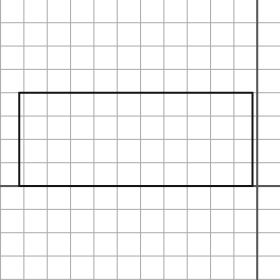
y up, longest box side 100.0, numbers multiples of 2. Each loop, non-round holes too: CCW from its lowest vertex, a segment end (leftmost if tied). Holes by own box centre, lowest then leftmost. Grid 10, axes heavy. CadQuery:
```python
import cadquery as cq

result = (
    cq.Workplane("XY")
    .moveTo(-102.0, 0.0)
    .lineTo(-2.0, 0.0)
    .lineTo(-2.0, 40.0)
    .lineTo(-102.0, 40.0)
    .close()
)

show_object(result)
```